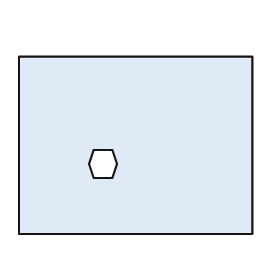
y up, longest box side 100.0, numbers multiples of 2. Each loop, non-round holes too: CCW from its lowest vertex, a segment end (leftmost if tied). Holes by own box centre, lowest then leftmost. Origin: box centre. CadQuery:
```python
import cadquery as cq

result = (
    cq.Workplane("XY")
    .moveTo(-50.0, -38.0)
    .lineTo(50.0, -38.0)
    .lineTo(50.0, 38.0)
    .lineTo(-50.0, 38.0)
    .close()
    .moveTo(-18.0, -14.0)
    .lineTo(-10.0, -14.0)
    .lineTo(-8.0, -8.0)
    .lineTo(-10.0, -2.0)
    .lineTo(-18.0, -2.0)
    .lineTo(-20.0, -8.0)
    .close()
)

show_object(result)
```